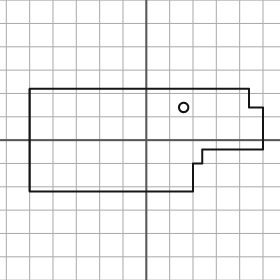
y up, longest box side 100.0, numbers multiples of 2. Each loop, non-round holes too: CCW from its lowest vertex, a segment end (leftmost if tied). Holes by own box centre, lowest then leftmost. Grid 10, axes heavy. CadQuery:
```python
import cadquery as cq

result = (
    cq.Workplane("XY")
    .moveTo(-50.0, -22.0)
    .lineTo(20.0, -22.0)
    .lineTo(20.0, -10.0)
    .lineTo(24.0, -10.0)
    .lineTo(24.0, -4.0)
    .lineTo(50.0, -4.0)
    .lineTo(50.0, 14.0)
    .lineTo(44.0, 14.0)
    .lineTo(44.0, 22.0)
    .lineTo(-50.0, 22.0)
    .close()
    .moveTo(16.0, 14.0)
    .circle(2.0)
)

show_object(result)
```